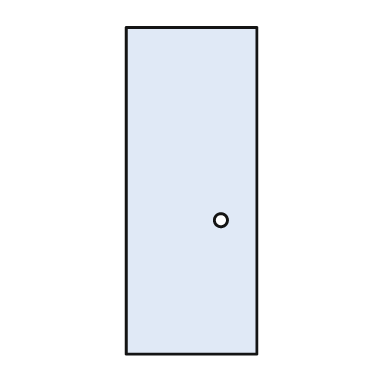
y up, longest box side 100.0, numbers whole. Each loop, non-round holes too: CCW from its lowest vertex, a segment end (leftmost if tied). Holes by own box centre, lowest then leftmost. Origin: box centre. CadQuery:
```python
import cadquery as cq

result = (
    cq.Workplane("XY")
    .moveTo(-20.0, -50.0)
    .lineTo(20.0, -50.0)
    .lineTo(20.0, 50.0)
    .lineTo(-20.0, 50.0)
    .close()
    .moveTo(9.0, -9.0)
    .circle(2.0)
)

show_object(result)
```